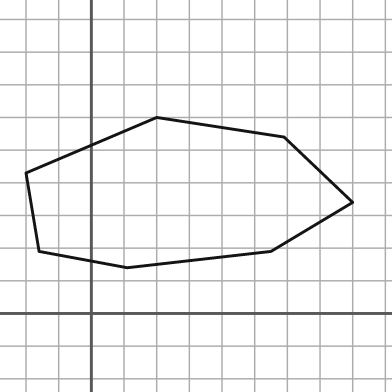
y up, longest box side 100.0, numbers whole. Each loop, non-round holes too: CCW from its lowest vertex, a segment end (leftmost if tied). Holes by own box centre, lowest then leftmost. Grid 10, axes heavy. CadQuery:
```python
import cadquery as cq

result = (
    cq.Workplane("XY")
    .moveTo(11.0, 14.0)
    .lineTo(55.0, 19.0)
    .lineTo(80.0, 34.0)
    .lineTo(59.0, 54.0)
    .lineTo(20.0, 60.0)
    .lineTo(-20.0, 43.0)
    .lineTo(-16.0, 19.0)
    .close()
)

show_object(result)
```